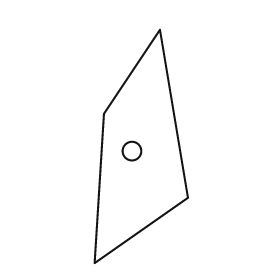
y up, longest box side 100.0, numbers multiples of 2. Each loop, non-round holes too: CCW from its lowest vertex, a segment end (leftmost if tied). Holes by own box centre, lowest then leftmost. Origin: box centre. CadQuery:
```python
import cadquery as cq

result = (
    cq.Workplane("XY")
    .moveTo(-20.0, -50.0)
    .lineTo(20.0, -22.0)
    .lineTo(8.0, 50.0)
    .lineTo(-16.0, 14.0)
    .close()
    .moveTo(-4.0, -2.0)
    .circle(4.0)
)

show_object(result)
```